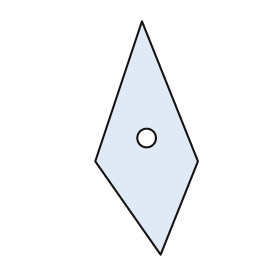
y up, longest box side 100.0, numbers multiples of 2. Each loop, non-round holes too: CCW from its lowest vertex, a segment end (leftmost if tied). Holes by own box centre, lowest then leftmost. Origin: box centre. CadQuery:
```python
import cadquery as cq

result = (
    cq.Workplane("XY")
    .moveTo(6.0, -50.0)
    .lineTo(22.0, -10.0)
    .lineTo(-2.0, 50.0)
    .lineTo(-22.0, -10.0)
    .close()
    .moveTo(0.0, 0.0)
    .circle(4.0)
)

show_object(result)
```